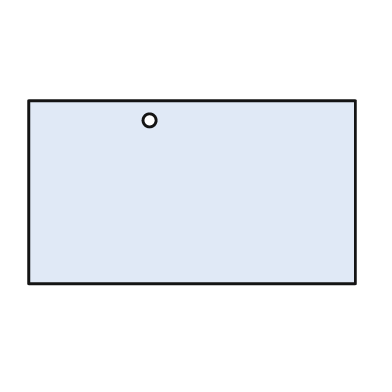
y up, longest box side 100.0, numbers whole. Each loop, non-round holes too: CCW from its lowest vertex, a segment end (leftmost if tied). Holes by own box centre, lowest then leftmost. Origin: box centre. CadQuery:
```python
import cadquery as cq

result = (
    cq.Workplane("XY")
    .moveTo(-50.0, -28.0)
    .lineTo(50.0, -28.0)
    .lineTo(50.0, 28.0)
    .lineTo(-50.0, 28.0)
    .close()
    .moveTo(-13.0, 22.0)
    .circle(2.0)
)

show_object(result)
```